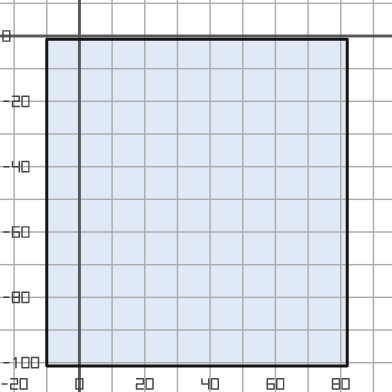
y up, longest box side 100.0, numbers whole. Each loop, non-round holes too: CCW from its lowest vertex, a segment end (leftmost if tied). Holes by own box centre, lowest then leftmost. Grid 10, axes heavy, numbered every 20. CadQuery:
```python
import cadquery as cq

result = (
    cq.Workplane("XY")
    .moveTo(-10.0, -101.0)
    .lineTo(82.0, -101.0)
    .lineTo(82.0, -1.0)
    .lineTo(-10.0, -1.0)
    .close()
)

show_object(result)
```